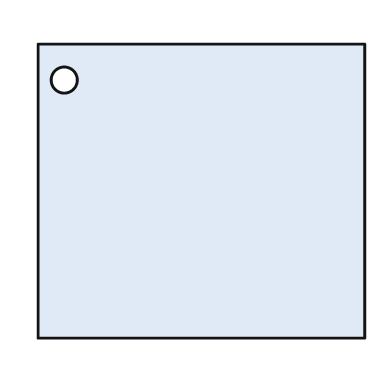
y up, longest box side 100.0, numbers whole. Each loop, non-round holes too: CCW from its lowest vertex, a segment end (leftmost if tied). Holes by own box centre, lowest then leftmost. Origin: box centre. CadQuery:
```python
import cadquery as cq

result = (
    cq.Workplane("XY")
    .moveTo(-50.0, -45.0)
    .lineTo(50.0, -45.0)
    .lineTo(50.0, 45.0)
    .lineTo(-50.0, 45.0)
    .close()
    .moveTo(-42.0, 34.0)
    .circle(4.0)
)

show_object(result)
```